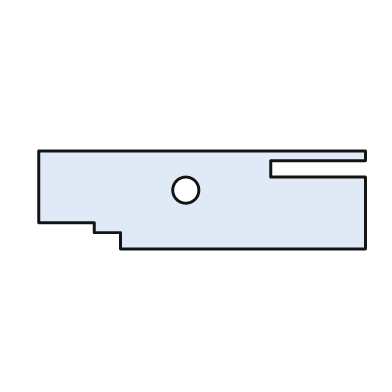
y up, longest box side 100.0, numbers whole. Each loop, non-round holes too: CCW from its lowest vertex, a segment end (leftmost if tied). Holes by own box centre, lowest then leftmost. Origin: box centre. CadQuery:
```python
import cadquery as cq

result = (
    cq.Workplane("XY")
    .moveTo(-25.0, -15.0)
    .lineTo(50.0, -15.0)
    .lineTo(50.0, 7.0)
    .lineTo(21.0, 7.0)
    .lineTo(21.0, 12.0)
    .lineTo(50.0, 12.0)
    .lineTo(50.0, 15.0)
    .lineTo(-50.0, 15.0)
    .lineTo(-50.0, -7.0)
    .lineTo(-33.0, -7.0)
    .lineTo(-33.0, -10.0)
    .lineTo(-25.0, -10.0)
    .close()
    .moveTo(-5.0, 3.0)
    .circle(4.0)
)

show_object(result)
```